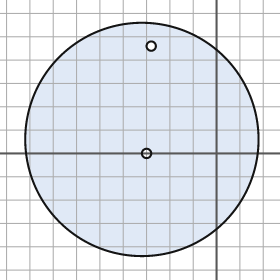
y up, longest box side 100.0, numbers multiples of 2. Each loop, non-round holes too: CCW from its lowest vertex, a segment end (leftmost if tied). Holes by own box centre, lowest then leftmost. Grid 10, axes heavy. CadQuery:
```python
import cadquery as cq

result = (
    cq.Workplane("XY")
    .moveTo(-32.0, 6.0)
    .circle(50.0)
    .moveTo(-30.0, 0.0)
    .circle(2.0)
    .moveTo(-28.0, 46.0)
    .circle(2.0)
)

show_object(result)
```